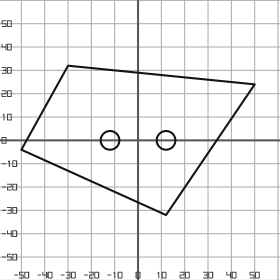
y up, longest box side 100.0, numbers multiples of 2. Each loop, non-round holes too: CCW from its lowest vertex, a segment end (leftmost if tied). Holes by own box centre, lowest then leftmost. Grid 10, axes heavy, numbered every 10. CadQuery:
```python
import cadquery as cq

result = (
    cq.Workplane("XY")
    .moveTo(12.0, -32.0)
    .lineTo(50.0, 24.0)
    .lineTo(-30.0, 32.0)
    .lineTo(-50.0, -4.0)
    .close()
    .moveTo(-12.0, 0.0)
    .circle(4.0)
    .moveTo(12.0, 0.0)
    .circle(4.0)
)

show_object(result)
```